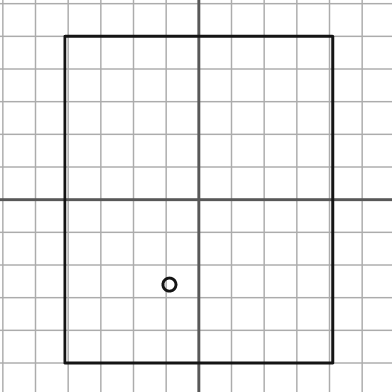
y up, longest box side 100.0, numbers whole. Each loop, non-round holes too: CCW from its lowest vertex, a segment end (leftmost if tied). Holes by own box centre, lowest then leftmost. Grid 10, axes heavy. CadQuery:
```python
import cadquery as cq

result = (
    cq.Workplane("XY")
    .moveTo(-41.0, -50.0)
    .lineTo(41.0, -50.0)
    .lineTo(41.0, 50.0)
    .lineTo(-41.0, 50.0)
    .close()
    .moveTo(-9.0, -26.0)
    .circle(2.0)
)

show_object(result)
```